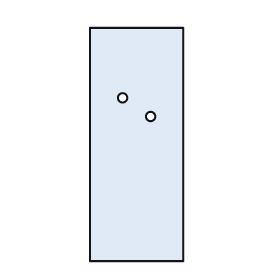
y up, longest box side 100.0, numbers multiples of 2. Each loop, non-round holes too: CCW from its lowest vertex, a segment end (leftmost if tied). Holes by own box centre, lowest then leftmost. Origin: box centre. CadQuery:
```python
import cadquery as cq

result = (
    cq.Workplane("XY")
    .moveTo(-20.0, -50.0)
    .lineTo(20.0, -50.0)
    .lineTo(20.0, 50.0)
    .lineTo(-20.0, 50.0)
    .close()
    .moveTo(6.0, 12.0)
    .circle(2.0)
    .moveTo(-6.0, 20.0)
    .circle(2.0)
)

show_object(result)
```